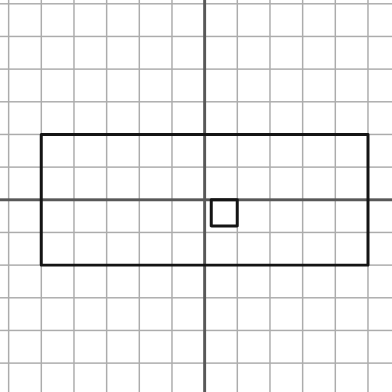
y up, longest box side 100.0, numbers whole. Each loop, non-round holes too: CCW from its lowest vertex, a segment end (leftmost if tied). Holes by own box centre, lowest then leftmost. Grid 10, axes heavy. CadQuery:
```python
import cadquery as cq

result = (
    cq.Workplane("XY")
    .moveTo(-50.0, -20.0)
    .lineTo(50.0, -20.0)
    .lineTo(50.0, 20.0)
    .lineTo(-50.0, 20.0)
    .close()
    .moveTo(2.0, -8.0)
    .lineTo(10.0, -8.0)
    .lineTo(10.0, 0.0)
    .lineTo(2.0, 0.0)
    .close()
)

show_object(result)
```